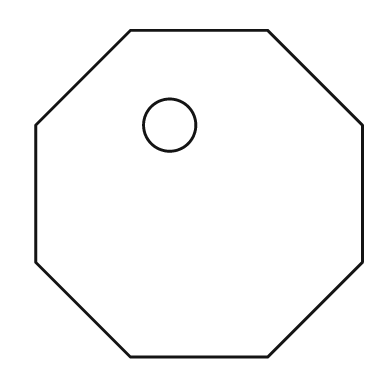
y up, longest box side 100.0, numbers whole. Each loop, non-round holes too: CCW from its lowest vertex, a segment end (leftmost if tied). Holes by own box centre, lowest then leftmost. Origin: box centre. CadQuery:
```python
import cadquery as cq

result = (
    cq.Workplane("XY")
    .moveTo(-21.0, -50.0)
    .lineTo(21.0, -50.0)
    .lineTo(50.0, -21.0)
    .lineTo(50.0, 21.0)
    .lineTo(21.0, 50.0)
    .lineTo(-21.0, 50.0)
    .lineTo(-50.0, 21.0)
    .lineTo(-50.0, -21.0)
    .close()
    .moveTo(-9.0, 21.0)
    .circle(8.0)
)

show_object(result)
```